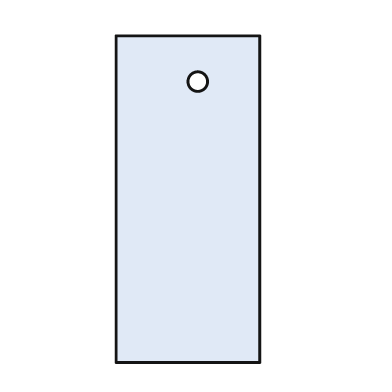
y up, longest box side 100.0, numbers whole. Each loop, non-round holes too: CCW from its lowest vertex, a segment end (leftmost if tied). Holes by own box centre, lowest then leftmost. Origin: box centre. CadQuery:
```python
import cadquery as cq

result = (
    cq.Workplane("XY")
    .moveTo(-22.0, -50.0)
    .lineTo(22.0, -50.0)
    .lineTo(22.0, 50.0)
    .lineTo(-22.0, 50.0)
    .close()
    .moveTo(3.0, 36.0)
    .circle(3.0)
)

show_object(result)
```